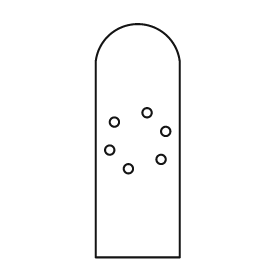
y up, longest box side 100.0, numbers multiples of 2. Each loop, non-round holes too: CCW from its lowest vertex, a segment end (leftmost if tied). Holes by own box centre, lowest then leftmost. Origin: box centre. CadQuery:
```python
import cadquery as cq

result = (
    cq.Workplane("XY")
    .moveTo(-18.0, -50.0)
    .lineTo(18.0, -50.0)
    .lineTo(18.0, 34.0)
    .threePointArc((0.0, 50.0), (-18.0, 34.0))
    .close()
    .moveTo(-4.0, -12.0)
    .circle(2.0)
    .moveTo(10.0, -8.0)
    .circle(2.0)
    .moveTo(-12.0, -4.0)
    .circle(2.0)
    .moveTo(12.0, 4.0)
    .circle(2.0)
    .moveTo(-10.0, 8.0)
    .circle(2.0)
    .moveTo(4.0, 12.0)
    .circle(2.0)
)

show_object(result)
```